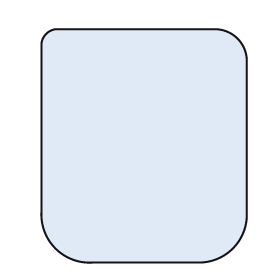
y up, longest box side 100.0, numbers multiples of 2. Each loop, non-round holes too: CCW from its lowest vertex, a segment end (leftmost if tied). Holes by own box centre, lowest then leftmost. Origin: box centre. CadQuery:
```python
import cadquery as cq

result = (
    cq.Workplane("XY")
    .moveTo(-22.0, -50.0)
    .lineTo(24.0, -50.0)
    .threePointArc((38.0, -44.0), (44.0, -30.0))
    .lineTo(44.0, 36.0)
    .threePointArc((40.0, 46.0), (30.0, 50.0))
    .lineTo(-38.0, 50.0)
    .threePointArc((-42.0, 48.0), (-44.0, 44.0))
    .lineTo(-44.0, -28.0)
    .threePointArc((-38.0, -44.0), (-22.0, -50.0))
    .close()
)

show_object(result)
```